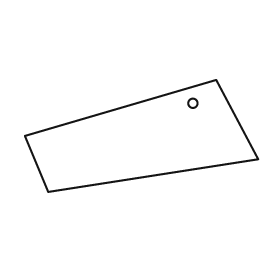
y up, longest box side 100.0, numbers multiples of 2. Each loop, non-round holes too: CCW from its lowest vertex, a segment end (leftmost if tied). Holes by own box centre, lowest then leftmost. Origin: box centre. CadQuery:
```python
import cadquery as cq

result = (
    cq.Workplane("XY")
    .moveTo(-40.0, -24.0)
    .lineTo(50.0, -10.0)
    .lineTo(32.0, 24.0)
    .lineTo(-50.0, 0.0)
    .close()
    .moveTo(22.0, 14.0)
    .circle(2.0)
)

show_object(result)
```